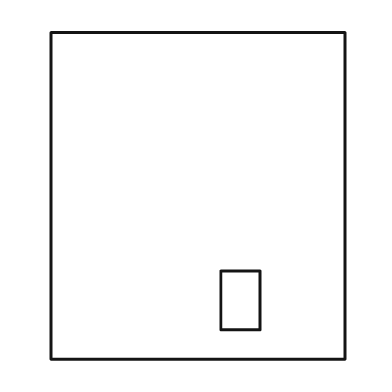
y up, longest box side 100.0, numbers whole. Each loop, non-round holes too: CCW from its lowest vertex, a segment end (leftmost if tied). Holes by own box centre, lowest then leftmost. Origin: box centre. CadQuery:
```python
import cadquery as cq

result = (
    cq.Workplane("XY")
    .moveTo(-45.0, -50.0)
    .lineTo(45.0, -50.0)
    .lineTo(45.0, 50.0)
    .lineTo(-45.0, 50.0)
    .close()
    .moveTo(7.0, -41.0)
    .lineTo(19.0, -41.0)
    .lineTo(19.0, -23.0)
    .lineTo(7.0, -23.0)
    .close()
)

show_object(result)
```